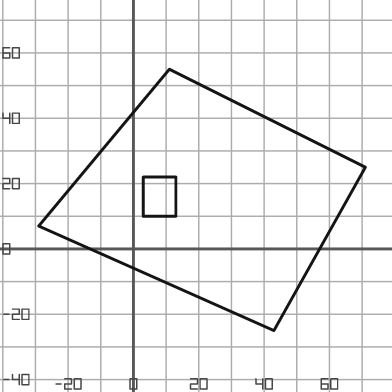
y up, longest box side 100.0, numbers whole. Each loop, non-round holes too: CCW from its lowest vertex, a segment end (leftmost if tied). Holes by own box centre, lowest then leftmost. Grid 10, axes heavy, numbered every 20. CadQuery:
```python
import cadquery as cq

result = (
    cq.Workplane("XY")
    .moveTo(43.0, -25.0)
    .lineTo(71.0, 25.0)
    .lineTo(11.0, 55.0)
    .lineTo(-29.0, 7.0)
    .close()
    .moveTo(3.0, 10.0)
    .lineTo(13.0, 10.0)
    .lineTo(13.0, 22.0)
    .lineTo(3.0, 22.0)
    .close()
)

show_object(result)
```